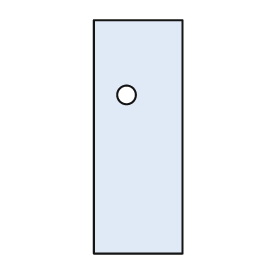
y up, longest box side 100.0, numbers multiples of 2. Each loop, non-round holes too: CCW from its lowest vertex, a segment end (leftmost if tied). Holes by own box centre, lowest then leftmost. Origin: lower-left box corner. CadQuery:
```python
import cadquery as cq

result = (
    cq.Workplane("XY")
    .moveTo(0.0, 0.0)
    .lineTo(38.0, 0.0)
    .lineTo(38.0, 100.0)
    .lineTo(0.0, 100.0)
    .close()
    .moveTo(14.0, 68.0)
    .circle(4.0)
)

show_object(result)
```